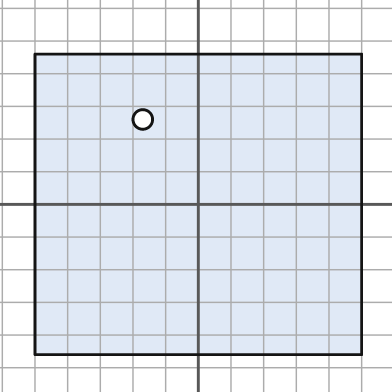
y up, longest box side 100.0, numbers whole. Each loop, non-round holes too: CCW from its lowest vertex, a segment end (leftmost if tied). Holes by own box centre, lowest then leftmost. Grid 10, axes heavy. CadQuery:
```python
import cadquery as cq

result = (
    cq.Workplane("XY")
    .moveTo(-50.0, -46.0)
    .lineTo(50.0, -46.0)
    .lineTo(50.0, 46.0)
    .lineTo(-50.0, 46.0)
    .close()
    .moveTo(-17.0, 26.0)
    .circle(3.0)
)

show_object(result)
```